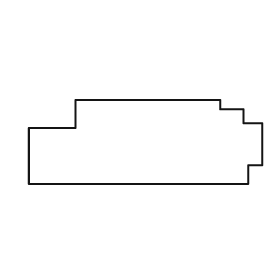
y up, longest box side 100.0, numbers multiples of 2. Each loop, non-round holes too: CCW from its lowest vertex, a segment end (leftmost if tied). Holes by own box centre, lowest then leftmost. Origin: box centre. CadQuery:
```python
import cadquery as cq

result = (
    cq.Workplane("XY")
    .moveTo(-50.0, -18.0)
    .lineTo(44.0, -18.0)
    .lineTo(44.0, -10.0)
    .lineTo(50.0, -10.0)
    .lineTo(50.0, 8.0)
    .lineTo(42.0, 8.0)
    .lineTo(42.0, 14.0)
    .lineTo(32.0, 14.0)
    .lineTo(32.0, 18.0)
    .lineTo(-30.0, 18.0)
    .lineTo(-30.0, 6.0)
    .lineTo(-50.0, 6.0)
    .close()
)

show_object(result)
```